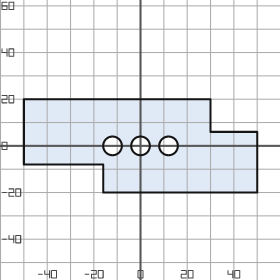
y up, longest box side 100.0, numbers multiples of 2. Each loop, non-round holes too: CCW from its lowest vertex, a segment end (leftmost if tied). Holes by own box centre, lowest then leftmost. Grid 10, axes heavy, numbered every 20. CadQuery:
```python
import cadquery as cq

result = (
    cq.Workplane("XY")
    .moveTo(-16.0, -20.0)
    .lineTo(50.0, -20.0)
    .lineTo(50.0, 6.0)
    .lineTo(30.0, 6.0)
    .lineTo(30.0, 20.0)
    .lineTo(-50.0, 20.0)
    .lineTo(-50.0, -8.0)
    .lineTo(-16.0, -8.0)
    .close()
    .moveTo(-12.0, 0.0)
    .circle(4.0)
    .moveTo(0.0, 0.0)
    .circle(4.0)
    .moveTo(12.0, 0.0)
    .circle(4.0)
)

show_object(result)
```